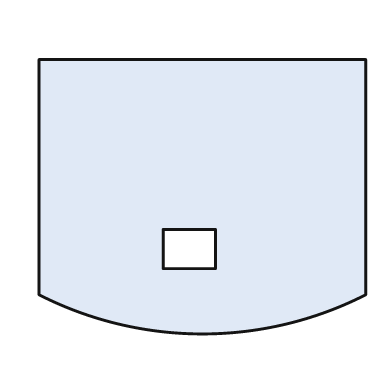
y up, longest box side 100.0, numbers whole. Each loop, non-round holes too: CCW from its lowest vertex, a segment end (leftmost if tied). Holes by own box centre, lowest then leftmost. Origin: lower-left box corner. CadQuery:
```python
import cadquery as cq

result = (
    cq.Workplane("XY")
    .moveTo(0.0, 12.0)
    .threePointArc((50.0, 0.0), (100.0, 12.0))
    .lineTo(100.0, 84.0)
    .lineTo(0.0, 84.0)
    .close()
    .moveTo(38.0, 20.0)
    .lineTo(54.0, 20.0)
    .lineTo(54.0, 32.0)
    .lineTo(38.0, 32.0)
    .close()
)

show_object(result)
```